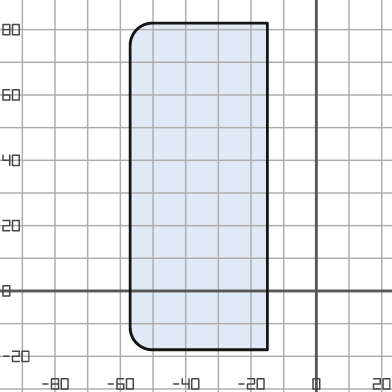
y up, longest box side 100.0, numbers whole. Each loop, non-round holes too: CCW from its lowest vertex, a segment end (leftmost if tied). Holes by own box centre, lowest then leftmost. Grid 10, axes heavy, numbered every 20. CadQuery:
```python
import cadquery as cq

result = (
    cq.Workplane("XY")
    .moveTo(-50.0, -18.0)
    .lineTo(-15.0, -18.0)
    .lineTo(-15.0, 82.0)
    .lineTo(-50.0, 82.0)
    .threePointArc((-55.0, 80.0), (-57.0, 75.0))
    .lineTo(-57.0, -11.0)
    .threePointArc((-55.0, -16.0), (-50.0, -18.0))
    .close()
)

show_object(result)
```